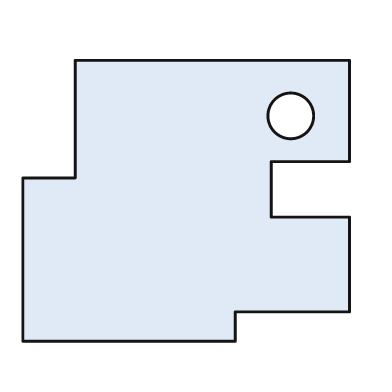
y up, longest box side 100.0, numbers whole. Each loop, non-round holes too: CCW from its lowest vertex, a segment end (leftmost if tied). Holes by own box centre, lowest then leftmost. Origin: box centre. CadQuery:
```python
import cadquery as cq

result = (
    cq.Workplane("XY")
    .moveTo(-50.0, -43.0)
    .lineTo(15.0, -43.0)
    .lineTo(15.0, -34.0)
    .lineTo(50.0, -34.0)
    .lineTo(50.0, -5.0)
    .lineTo(26.0, -5.0)
    .lineTo(26.0, 12.0)
    .lineTo(50.0, 12.0)
    .lineTo(50.0, 43.0)
    .lineTo(-34.0, 43.0)
    .lineTo(-34.0, 7.0)
    .lineTo(-50.0, 7.0)
    .close()
    .moveTo(32.0, 26.0)
    .circle(7.0)
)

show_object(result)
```